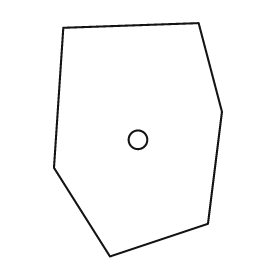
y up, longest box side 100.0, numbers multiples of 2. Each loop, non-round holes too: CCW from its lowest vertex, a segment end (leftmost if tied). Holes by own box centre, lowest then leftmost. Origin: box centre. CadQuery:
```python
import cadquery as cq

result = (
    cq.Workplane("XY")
    .moveTo(-12.0, -50.0)
    .lineTo(30.0, -36.0)
    .lineTo(36.0, 12.0)
    .lineTo(26.0, 50.0)
    .lineTo(-32.0, 48.0)
    .lineTo(-36.0, -12.0)
    .close()
    .moveTo(0.0, 0.0)
    .circle(4.0)
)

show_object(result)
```